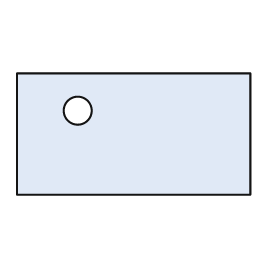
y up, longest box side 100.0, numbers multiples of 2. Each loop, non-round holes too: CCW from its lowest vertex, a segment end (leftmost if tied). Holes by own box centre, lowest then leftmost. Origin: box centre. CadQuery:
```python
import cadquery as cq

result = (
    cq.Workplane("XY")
    .moveTo(-50.0, -26.0)
    .lineTo(50.0, -26.0)
    .lineTo(50.0, 26.0)
    .lineTo(-50.0, 26.0)
    .close()
    .moveTo(-24.0, 10.0)
    .circle(6.0)
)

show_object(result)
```